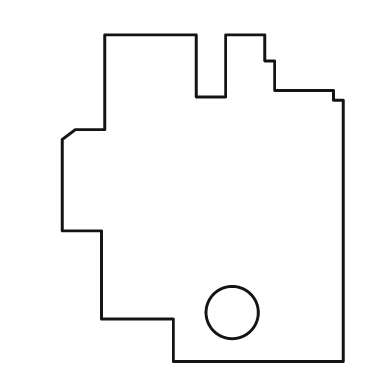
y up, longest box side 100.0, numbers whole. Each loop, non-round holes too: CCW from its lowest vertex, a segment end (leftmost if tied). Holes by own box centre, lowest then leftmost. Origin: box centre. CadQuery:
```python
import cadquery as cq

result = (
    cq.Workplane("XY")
    .moveTo(-9.0, -50.0)
    .lineTo(43.0, -50.0)
    .lineTo(43.0, 30.0)
    .lineTo(40.0, 30.0)
    .lineTo(40.0, 33.0)
    .lineTo(22.0, 33.0)
    .lineTo(22.0, 42.0)
    .lineTo(19.0, 42.0)
    .lineTo(19.0, 50.0)
    .lineTo(7.0, 50.0)
    .lineTo(7.0, 31.0)
    .lineTo(-2.0, 31.0)
    .lineTo(-2.0, 50.0)
    .lineTo(-30.0, 50.0)
    .lineTo(-30.0, 21.0)
    .lineTo(-39.0, 21.0)
    .lineTo(-43.0, 18.0)
    .lineTo(-43.0, -10.0)
    .lineTo(-31.0, -10.0)
    .lineTo(-31.0, -37.0)
    .lineTo(-9.0, -37.0)
    .close()
    .moveTo(9.0, -35.0)
    .circle(8.0)
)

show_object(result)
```